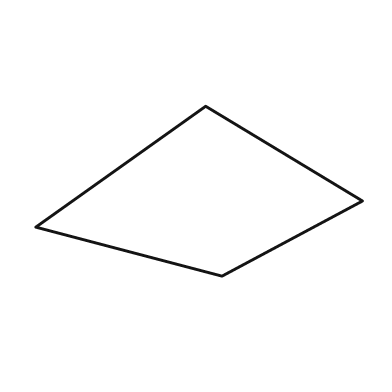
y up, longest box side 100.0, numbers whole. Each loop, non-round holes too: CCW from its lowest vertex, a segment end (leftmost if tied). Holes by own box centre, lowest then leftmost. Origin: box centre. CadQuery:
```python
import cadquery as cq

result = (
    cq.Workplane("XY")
    .moveTo(7.0, -26.0)
    .lineTo(50.0, -3.0)
    .lineTo(2.0, 26.0)
    .lineTo(-50.0, -11.0)
    .close()
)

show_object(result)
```